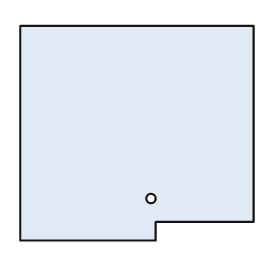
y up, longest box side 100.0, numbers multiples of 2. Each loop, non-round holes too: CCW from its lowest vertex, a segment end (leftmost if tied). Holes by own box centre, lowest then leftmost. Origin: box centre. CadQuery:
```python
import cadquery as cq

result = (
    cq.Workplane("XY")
    .moveTo(-50.0, -46.0)
    .lineTo(8.0, -46.0)
    .lineTo(8.0, -38.0)
    .lineTo(50.0, -38.0)
    .lineTo(50.0, 46.0)
    .lineTo(-50.0, 46.0)
    .close()
    .moveTo(6.0, -28.0)
    .circle(2.0)
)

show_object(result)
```